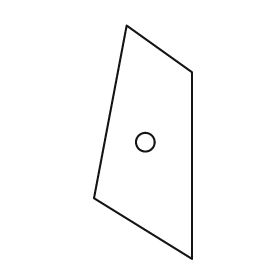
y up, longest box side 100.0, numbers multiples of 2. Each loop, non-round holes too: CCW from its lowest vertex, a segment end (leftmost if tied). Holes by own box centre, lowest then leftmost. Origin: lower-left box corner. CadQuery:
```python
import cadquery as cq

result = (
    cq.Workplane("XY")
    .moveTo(42.0, 0.0)
    .lineTo(42.0, 80.0)
    .lineTo(14.0, 100.0)
    .lineTo(0.0, 26.0)
    .close()
    .moveTo(22.0, 50.0)
    .circle(4.0)
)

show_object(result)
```